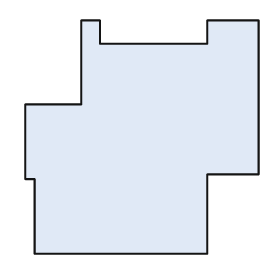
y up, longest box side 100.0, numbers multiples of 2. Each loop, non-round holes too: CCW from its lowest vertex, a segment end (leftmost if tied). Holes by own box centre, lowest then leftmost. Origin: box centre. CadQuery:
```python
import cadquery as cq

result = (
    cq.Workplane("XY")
    .moveTo(-46.0, -50.0)
    .lineTo(28.0, -50.0)
    .lineTo(28.0, -16.0)
    .lineTo(50.0, -16.0)
    .lineTo(50.0, 50.0)
    .lineTo(28.0, 50.0)
    .lineTo(28.0, 40.0)
    .lineTo(-18.0, 40.0)
    .lineTo(-18.0, 50.0)
    .lineTo(-26.0, 50.0)
    .lineTo(-26.0, 14.0)
    .lineTo(-50.0, 14.0)
    .lineTo(-50.0, -18.0)
    .lineTo(-46.0, -18.0)
    .close()
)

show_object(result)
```